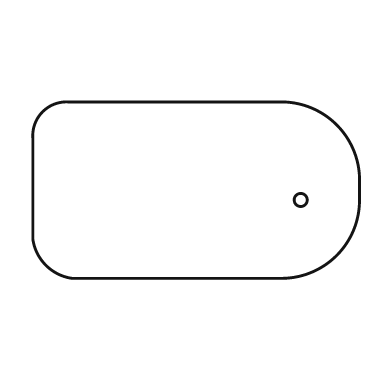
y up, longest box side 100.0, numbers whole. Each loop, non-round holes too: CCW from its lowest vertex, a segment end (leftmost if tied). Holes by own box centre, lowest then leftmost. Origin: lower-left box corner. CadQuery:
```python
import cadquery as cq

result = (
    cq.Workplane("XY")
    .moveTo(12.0, 0.0)
    .lineTo(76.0, 0.0)
    .threePointArc((93.0, 7.0), (100.0, 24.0))
    .lineTo(100.0, 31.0)
    .threePointArc((93.0, 47.0), (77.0, 54.0))
    .lineTo(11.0, 54.0)
    .threePointArc((3.0, 51.0), (0.0, 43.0))
    .lineTo(0.0, 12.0)
    .threePointArc((4.0, 4.0), (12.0, 0.0))
    .close()
    .moveTo(82.0, 24.0)
    .circle(2.0)
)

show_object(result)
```